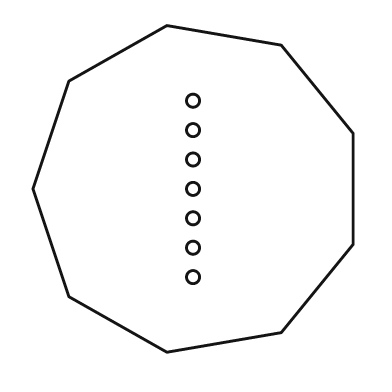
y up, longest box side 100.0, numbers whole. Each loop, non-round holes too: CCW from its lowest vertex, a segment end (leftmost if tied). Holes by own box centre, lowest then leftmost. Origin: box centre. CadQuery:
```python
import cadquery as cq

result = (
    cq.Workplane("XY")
    .moveTo(-8.0, -50.0)
    .lineTo(27.0, -44.0)
    .lineTo(49.0, -17.0)
    .lineTo(49.0, 17.0)
    .lineTo(27.0, 44.0)
    .lineTo(-8.0, 50.0)
    .lineTo(-38.0, 33.0)
    .lineTo(-49.0, 0.0)
    .lineTo(-38.0, -33.0)
    .close()
    .moveTo(0.0, -27.0)
    .circle(2.0)
    .moveTo(0.0, -18.0)
    .circle(2.0)
    .moveTo(0.0, -9.0)
    .circle(2.0)
    .moveTo(0.0, 0.0)
    .circle(2.0)
    .moveTo(0.0, 9.0)
    .circle(2.0)
    .moveTo(0.0, 18.0)
    .circle(2.0)
    .moveTo(0.0, 27.0)
    .circle(2.0)
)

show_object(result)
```